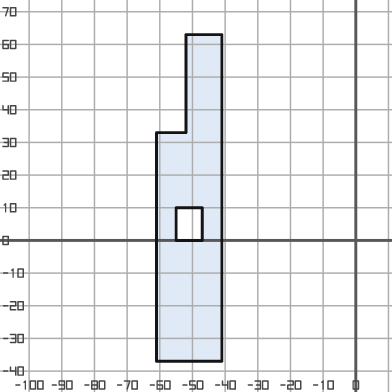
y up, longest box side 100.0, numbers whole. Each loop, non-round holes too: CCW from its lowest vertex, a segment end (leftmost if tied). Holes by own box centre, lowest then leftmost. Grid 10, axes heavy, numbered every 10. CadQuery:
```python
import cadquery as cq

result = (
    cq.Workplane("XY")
    .moveTo(-61.0, -37.0)
    .lineTo(-41.0, -37.0)
    .lineTo(-41.0, 63.0)
    .lineTo(-52.0, 63.0)
    .lineTo(-52.0, 33.0)
    .lineTo(-61.0, 33.0)
    .close()
    .moveTo(-55.0, 0.0)
    .lineTo(-47.0, 0.0)
    .lineTo(-47.0, 10.0)
    .lineTo(-55.0, 10.0)
    .close()
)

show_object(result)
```